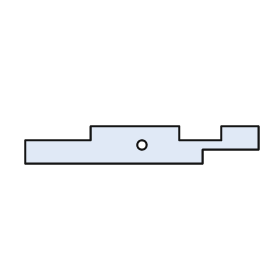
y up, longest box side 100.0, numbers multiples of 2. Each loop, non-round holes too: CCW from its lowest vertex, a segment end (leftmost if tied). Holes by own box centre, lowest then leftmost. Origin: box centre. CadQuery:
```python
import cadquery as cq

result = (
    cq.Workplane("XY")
    .moveTo(-50.0, -8.0)
    .lineTo(26.0, -8.0)
    .lineTo(26.0, -2.0)
    .lineTo(50.0, -2.0)
    .lineTo(50.0, 8.0)
    .lineTo(34.0, 8.0)
    .lineTo(34.0, 2.0)
    .lineTo(16.0, 2.0)
    .lineTo(16.0, 8.0)
    .lineTo(-22.0, 8.0)
    .lineTo(-22.0, 2.0)
    .lineTo(-50.0, 2.0)
    .close()
    .moveTo(0.0, 0.0)
    .circle(2.0)
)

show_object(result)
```